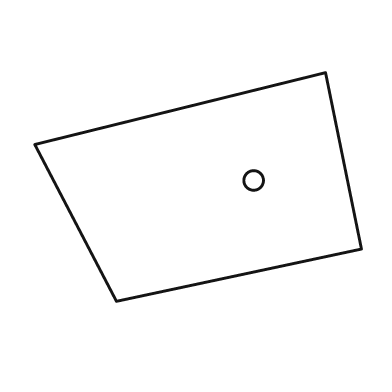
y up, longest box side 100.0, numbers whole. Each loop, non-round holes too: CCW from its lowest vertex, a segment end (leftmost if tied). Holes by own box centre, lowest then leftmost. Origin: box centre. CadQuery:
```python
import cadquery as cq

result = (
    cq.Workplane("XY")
    .moveTo(-25.0, -35.0)
    .lineTo(50.0, -19.0)
    .lineTo(39.0, 35.0)
    .lineTo(-50.0, 13.0)
    .close()
    .moveTo(17.0, 2.0)
    .circle(3.0)
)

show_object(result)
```